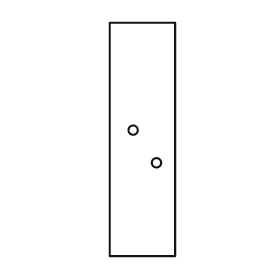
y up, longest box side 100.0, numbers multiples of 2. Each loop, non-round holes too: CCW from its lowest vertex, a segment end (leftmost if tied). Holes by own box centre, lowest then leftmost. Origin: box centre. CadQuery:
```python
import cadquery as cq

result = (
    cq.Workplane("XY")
    .moveTo(-14.0, -50.0)
    .lineTo(14.0, -50.0)
    .lineTo(14.0, 50.0)
    .lineTo(-14.0, 50.0)
    .close()
    .moveTo(6.0, -10.0)
    .circle(2.0)
    .moveTo(-4.0, 4.0)
    .circle(2.0)
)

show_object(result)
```